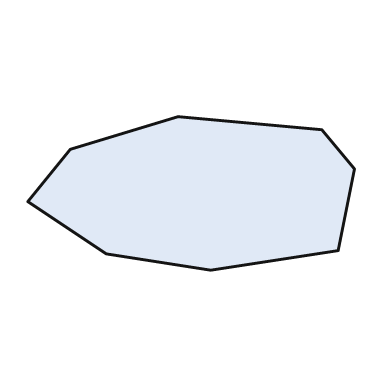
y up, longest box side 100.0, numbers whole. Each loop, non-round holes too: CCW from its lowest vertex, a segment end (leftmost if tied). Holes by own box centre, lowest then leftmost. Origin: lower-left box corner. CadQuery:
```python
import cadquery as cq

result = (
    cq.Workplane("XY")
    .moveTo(56.0, 0.0)
    .lineTo(95.0, 6.0)
    .lineTo(100.0, 31.0)
    .lineTo(90.0, 43.0)
    .lineTo(46.0, 47.0)
    .lineTo(13.0, 37.0)
    .lineTo(0.0, 21.0)
    .lineTo(24.0, 5.0)
    .close()
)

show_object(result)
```